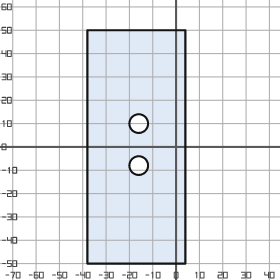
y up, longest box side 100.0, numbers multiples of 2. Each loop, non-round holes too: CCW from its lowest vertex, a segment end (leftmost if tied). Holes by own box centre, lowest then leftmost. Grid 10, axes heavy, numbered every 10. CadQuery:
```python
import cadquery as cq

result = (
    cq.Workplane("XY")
    .moveTo(-38.0, -50.0)
    .lineTo(4.0, -50.0)
    .lineTo(4.0, 50.0)
    .lineTo(-38.0, 50.0)
    .close()
    .moveTo(-16.0, -8.0)
    .circle(4.0)
    .moveTo(-16.0, 10.0)
    .circle(4.0)
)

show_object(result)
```